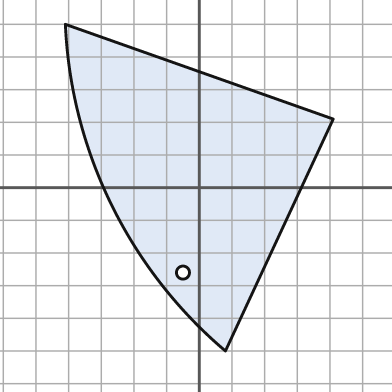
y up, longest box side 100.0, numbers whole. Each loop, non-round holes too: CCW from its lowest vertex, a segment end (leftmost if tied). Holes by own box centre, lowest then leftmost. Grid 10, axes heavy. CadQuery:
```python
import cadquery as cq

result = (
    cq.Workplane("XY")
    .moveTo(8.0, -50.0)
    .lineTo(41.0, 21.0)
    .lineTo(-41.0, 50.0)
    .threePointArc((-27.0, -5.0), (8.0, -50.0))
    .close()
    .moveTo(-5.0, -26.0)
    .circle(2.0)
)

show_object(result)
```